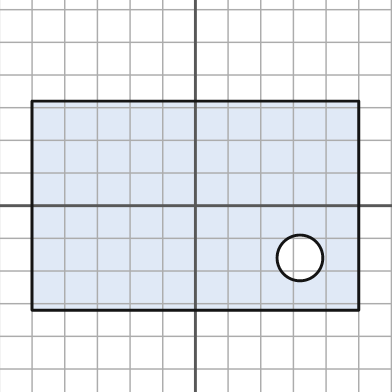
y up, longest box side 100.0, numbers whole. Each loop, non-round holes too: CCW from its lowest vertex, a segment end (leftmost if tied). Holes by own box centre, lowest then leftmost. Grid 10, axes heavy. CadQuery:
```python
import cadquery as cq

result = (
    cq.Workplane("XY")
    .moveTo(-50.0, -32.0)
    .lineTo(50.0, -32.0)
    .lineTo(50.0, 32.0)
    .lineTo(-50.0, 32.0)
    .close()
    .moveTo(32.0, -16.0)
    .circle(7.0)
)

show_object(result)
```